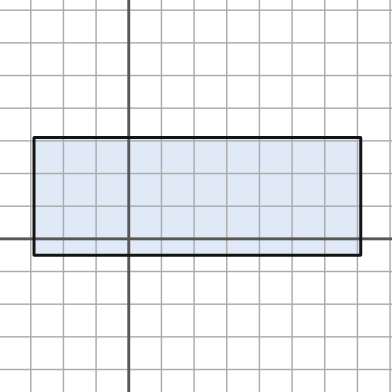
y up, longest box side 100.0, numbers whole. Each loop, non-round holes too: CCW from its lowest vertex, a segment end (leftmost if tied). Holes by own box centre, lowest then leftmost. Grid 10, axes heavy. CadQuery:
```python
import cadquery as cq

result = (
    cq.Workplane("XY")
    .moveTo(-29.0, -5.0)
    .lineTo(71.0, -5.0)
    .lineTo(71.0, 31.0)
    .lineTo(-29.0, 31.0)
    .close()
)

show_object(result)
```